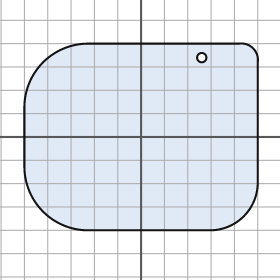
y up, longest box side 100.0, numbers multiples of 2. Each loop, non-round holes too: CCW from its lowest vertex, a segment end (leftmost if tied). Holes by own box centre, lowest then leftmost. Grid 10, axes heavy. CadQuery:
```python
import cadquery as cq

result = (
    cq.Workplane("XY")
    .moveTo(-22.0, -40.0)
    .lineTo(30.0, -40.0)
    .threePointArc((44.0, -34.0), (50.0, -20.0))
    .lineTo(50.0, 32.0)
    .threePointArc((48.0, 38.0), (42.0, 40.0))
    .lineTo(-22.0, 40.0)
    .threePointArc((-42.0, 32.0), (-50.0, 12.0))
    .lineTo(-50.0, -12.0)
    .threePointArc((-42.0, -32.0), (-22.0, -40.0))
    .close()
    .moveTo(26.0, 34.0)
    .circle(2.0)
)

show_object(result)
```